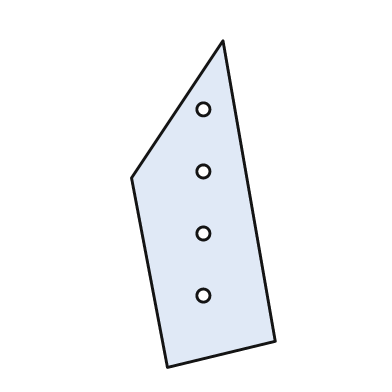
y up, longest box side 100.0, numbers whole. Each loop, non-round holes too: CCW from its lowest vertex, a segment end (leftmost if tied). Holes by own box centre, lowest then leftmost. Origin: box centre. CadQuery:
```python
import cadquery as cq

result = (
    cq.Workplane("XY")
    .moveTo(-11.0, -50.0)
    .lineTo(22.0, -42.0)
    .lineTo(6.0, 50.0)
    .lineTo(-22.0, 8.0)
    .close()
    .moveTo(0.0, -28.0)
    .circle(2.0)
    .moveTo(0.0, -9.0)
    .circle(2.0)
    .moveTo(0.0, 10.0)
    .circle(2.0)
    .moveTo(0.0, 29.0)
    .circle(2.0)
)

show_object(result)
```